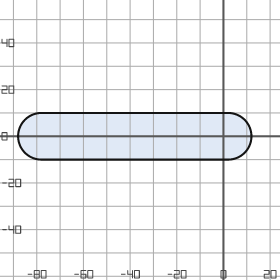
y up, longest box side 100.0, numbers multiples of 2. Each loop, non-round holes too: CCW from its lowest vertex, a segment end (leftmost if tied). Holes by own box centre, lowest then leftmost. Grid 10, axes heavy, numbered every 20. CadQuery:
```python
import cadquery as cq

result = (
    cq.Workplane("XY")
    .moveTo(-78.0, -10.0)
    .lineTo(2.0, -10.0)
    .threePointArc((12.0, 0.0), (2.0, 10.0))
    .lineTo(-78.0, 10.0)
    .threePointArc((-88.0, 0.0), (-78.0, -10.0))
    .close()
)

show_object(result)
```